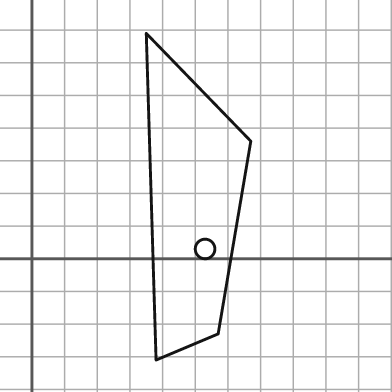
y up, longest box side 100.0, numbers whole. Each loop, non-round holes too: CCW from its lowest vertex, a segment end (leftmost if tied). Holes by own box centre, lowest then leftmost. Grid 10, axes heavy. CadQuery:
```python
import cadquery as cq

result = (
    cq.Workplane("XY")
    .moveTo(38.0, -31.0)
    .lineTo(57.0, -23.0)
    .lineTo(67.0, 36.0)
    .lineTo(35.0, 69.0)
    .close()
    .moveTo(53.0, 3.0)
    .circle(3.0)
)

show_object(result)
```